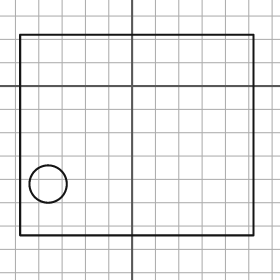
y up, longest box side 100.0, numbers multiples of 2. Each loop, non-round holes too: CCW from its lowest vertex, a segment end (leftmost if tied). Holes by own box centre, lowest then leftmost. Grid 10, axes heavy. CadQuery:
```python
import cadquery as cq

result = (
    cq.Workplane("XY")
    .moveTo(-48.0, -64.0)
    .lineTo(52.0, -64.0)
    .lineTo(52.0, 22.0)
    .lineTo(-48.0, 22.0)
    .close()
    .moveTo(-36.0, -42.0)
    .circle(8.0)
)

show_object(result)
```